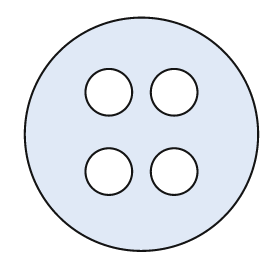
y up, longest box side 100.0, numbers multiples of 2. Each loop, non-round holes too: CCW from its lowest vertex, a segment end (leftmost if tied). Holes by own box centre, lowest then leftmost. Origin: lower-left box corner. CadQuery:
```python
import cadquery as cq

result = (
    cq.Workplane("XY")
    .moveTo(50.0, 50.0)
    .circle(50.0)
    .moveTo(36.0, 34.0)
    .circle(10.0)
    .moveTo(64.0, 34.0)
    .circle(10.0)
    .moveTo(36.0, 68.0)
    .circle(10.0)
    .moveTo(64.0, 68.0)
    .circle(10.0)
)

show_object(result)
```